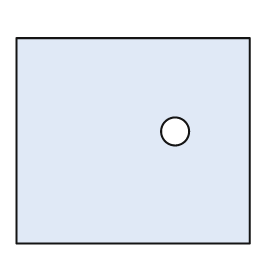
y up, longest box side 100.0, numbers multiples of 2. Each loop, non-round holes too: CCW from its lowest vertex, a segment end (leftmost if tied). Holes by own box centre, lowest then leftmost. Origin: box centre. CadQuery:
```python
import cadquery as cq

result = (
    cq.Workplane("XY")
    .moveTo(-50.0, -44.0)
    .lineTo(50.0, -44.0)
    .lineTo(50.0, 44.0)
    .lineTo(-50.0, 44.0)
    .close()
    .moveTo(18.0, 4.0)
    .circle(6.0)
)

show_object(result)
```